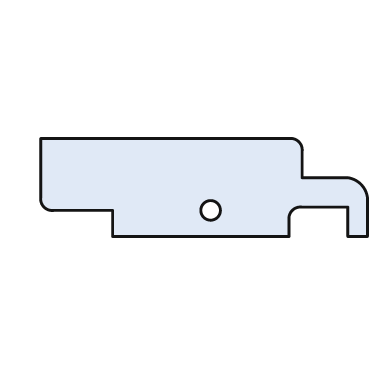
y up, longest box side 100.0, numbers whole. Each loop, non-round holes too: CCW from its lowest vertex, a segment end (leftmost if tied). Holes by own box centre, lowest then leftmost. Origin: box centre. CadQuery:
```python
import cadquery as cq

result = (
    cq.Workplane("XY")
    .moveTo(-28.0, -15.0)
    .lineTo(26.0, -15.0)
    .lineTo(26.0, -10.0)
    .threePointArc((27.0, -7.0), (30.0, -6.0))
    .lineTo(44.0, -6.0)
    .lineTo(44.0, -15.0)
    .lineTo(50.0, -15.0)
    .lineTo(50.0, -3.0)
    .threePointArc((48.0, 1.0), (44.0, 3.0))
    .lineTo(30.0, 3.0)
    .lineTo(30.0, 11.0)
    .threePointArc((29.0, 14.0), (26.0, 15.0))
    .lineTo(-50.0, 15.0)
    .lineTo(-50.0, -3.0)
    .threePointArc((-49.0, -6.0), (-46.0, -7.0))
    .lineTo(-28.0, -7.0)
    .close()
    .moveTo(2.0, -7.0)
    .circle(3.0)
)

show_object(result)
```